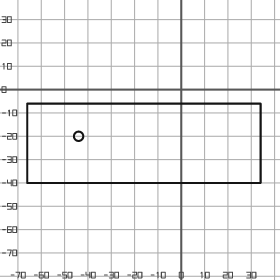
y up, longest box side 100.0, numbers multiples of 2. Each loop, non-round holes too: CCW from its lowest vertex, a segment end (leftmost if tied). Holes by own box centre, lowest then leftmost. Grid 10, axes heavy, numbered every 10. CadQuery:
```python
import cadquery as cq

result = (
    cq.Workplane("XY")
    .moveTo(-66.0, -40.0)
    .lineTo(34.0, -40.0)
    .lineTo(34.0, -6.0)
    .lineTo(-66.0, -6.0)
    .close()
    .moveTo(-44.0, -20.0)
    .circle(2.0)
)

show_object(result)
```